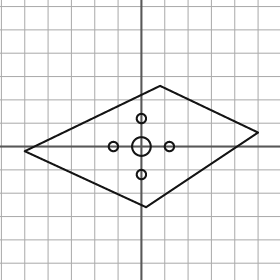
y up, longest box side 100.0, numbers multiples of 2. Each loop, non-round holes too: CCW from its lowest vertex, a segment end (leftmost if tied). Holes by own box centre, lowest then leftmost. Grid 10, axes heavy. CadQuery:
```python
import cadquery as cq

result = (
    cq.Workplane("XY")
    .moveTo(2.0, -26.0)
    .lineTo(50.0, 6.0)
    .lineTo(8.0, 26.0)
    .lineTo(-50.0, -2.0)
    .close()
    .moveTo(0.0, -12.0)
    .circle(2.0)
    .moveTo(-12.0, 0.0)
    .circle(2.0)
    .moveTo(0.0, 0.0)
    .circle(4.0)
    .moveTo(12.0, 0.0)
    .circle(2.0)
    .moveTo(0.0, 12.0)
    .circle(2.0)
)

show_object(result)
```